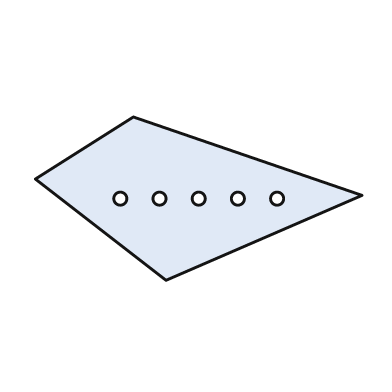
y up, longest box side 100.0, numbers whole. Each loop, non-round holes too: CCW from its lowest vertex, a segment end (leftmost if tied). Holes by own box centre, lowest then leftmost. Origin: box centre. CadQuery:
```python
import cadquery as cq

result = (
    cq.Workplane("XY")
    .moveTo(-10.0, -25.0)
    .lineTo(50.0, 1.0)
    .lineTo(-20.0, 25.0)
    .lineTo(-50.0, 6.0)
    .close()
    .moveTo(-24.0, 0.0)
    .circle(2.0)
    .moveTo(-12.0, 0.0)
    .circle(2.0)
    .moveTo(0.0, 0.0)
    .circle(2.0)
    .moveTo(12.0, 0.0)
    .circle(2.0)
    .moveTo(24.0, 0.0)
    .circle(2.0)
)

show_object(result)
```